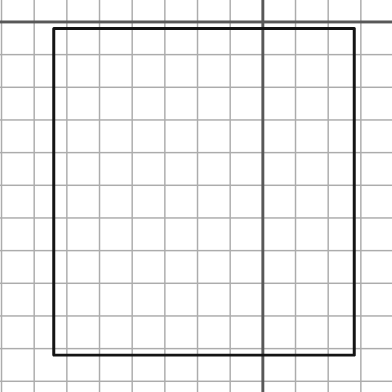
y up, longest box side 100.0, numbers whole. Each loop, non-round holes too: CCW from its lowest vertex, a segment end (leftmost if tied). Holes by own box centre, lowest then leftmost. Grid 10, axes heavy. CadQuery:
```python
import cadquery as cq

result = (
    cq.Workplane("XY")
    .moveTo(-64.0, -102.0)
    .lineTo(28.0, -102.0)
    .lineTo(28.0, -2.0)
    .lineTo(-64.0, -2.0)
    .close()
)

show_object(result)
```